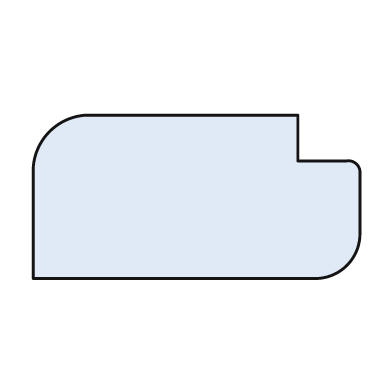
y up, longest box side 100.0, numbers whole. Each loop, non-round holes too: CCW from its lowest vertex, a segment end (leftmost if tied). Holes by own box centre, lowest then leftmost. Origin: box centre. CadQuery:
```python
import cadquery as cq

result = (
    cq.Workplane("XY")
    .moveTo(-50.0, -25.0)
    .lineTo(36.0, -25.0)
    .threePointArc((46.0, -21.0), (50.0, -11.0))
    .lineTo(50.0, 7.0)
    .threePointArc((49.0, 10.0), (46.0, 11.0))
    .lineTo(31.0, 11.0)
    .lineTo(31.0, 25.0)
    .lineTo(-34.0, 25.0)
    .threePointArc((-45.0, 20.0), (-50.0, 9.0))
    .close()
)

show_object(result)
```